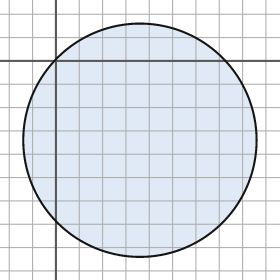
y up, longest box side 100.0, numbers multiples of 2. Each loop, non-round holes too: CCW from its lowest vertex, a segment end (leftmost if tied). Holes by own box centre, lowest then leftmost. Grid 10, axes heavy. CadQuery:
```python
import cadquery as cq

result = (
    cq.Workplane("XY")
    .moveTo(36.0, -34.0)
    .circle(50.0)
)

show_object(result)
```